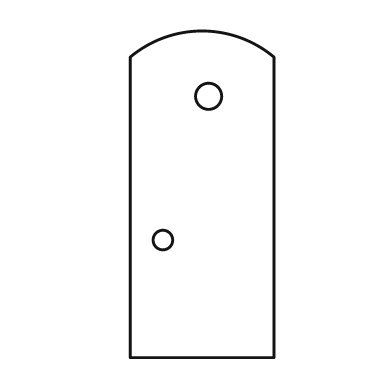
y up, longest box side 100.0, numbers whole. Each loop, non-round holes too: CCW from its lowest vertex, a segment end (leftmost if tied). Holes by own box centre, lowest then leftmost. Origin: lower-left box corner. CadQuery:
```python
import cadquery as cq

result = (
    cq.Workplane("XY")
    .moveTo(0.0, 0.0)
    .lineTo(44.0, 0.0)
    .lineTo(44.0, 92.0)
    .threePointArc((22.0, 100.0), (0.0, 92.0))
    .close()
    .moveTo(10.0, 36.0)
    .circle(3.0)
    .moveTo(24.0, 80.0)
    .circle(4.0)
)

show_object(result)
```